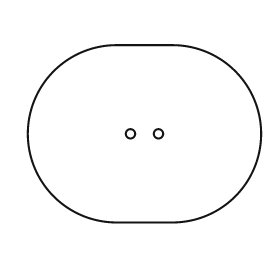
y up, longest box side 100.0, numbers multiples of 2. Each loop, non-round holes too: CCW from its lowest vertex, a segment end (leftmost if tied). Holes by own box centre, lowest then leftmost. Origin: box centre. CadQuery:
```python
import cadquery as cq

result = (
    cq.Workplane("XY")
    .moveTo(-12.0, -38.0)
    .lineTo(12.0, -38.0)
    .threePointArc((50.0, 0.0), (12.0, 38.0))
    .lineTo(-12.0, 38.0)
    .threePointArc((-50.0, 0.0), (-12.0, -38.0))
    .close()
    .moveTo(-6.0, 0.0)
    .circle(2.0)
    .moveTo(6.0, 0.0)
    .circle(2.0)
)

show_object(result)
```